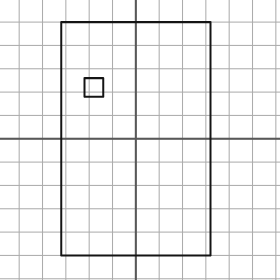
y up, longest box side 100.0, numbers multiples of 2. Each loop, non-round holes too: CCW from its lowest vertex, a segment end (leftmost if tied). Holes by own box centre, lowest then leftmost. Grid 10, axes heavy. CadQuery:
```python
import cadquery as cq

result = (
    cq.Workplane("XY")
    .moveTo(-32.0, -50.0)
    .lineTo(32.0, -50.0)
    .lineTo(32.0, 50.0)
    .lineTo(-32.0, 50.0)
    .close()
    .moveTo(-22.0, 18.0)
    .lineTo(-14.0, 18.0)
    .lineTo(-14.0, 26.0)
    .lineTo(-22.0, 26.0)
    .close()
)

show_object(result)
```